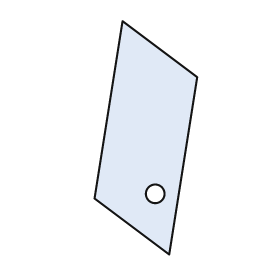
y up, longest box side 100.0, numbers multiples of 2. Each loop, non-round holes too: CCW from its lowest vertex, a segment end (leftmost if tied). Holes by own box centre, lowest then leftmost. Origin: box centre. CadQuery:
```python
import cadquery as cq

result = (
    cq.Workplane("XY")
    .moveTo(10.0, -50.0)
    .lineTo(22.0, 26.0)
    .lineTo(-10.0, 50.0)
    .lineTo(-22.0, -26.0)
    .close()
    .moveTo(4.0, -24.0)
    .circle(4.0)
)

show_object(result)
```